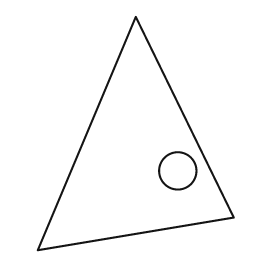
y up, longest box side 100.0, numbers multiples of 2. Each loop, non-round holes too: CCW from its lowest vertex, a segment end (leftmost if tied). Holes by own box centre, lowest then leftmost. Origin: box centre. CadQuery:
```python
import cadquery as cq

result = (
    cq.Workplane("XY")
    .moveTo(-42.0, -50.0)
    .lineTo(42.0, -36.0)
    .lineTo(0.0, 50.0)
    .close()
    .moveTo(18.0, -16.0)
    .circle(8.0)
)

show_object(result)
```